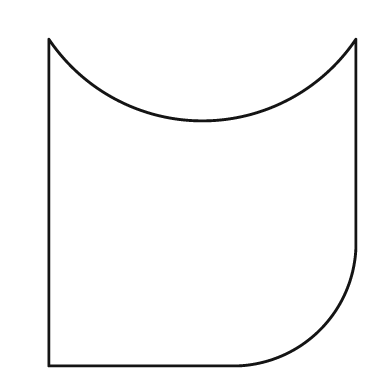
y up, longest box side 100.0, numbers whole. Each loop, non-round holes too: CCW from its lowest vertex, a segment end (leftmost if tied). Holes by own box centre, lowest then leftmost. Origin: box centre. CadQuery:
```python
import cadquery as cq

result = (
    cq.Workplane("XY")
    .moveTo(-47.0, -50.0)
    .lineTo(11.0, -50.0)
    .threePointArc((36.0, -39.0), (47.0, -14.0))
    .lineTo(47.0, 50.0)
    .threePointArc((0.0, 25.0), (-47.0, 50.0))
    .close()
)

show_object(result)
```